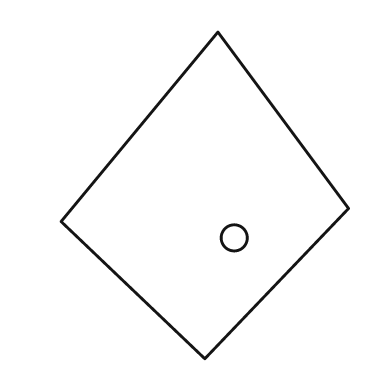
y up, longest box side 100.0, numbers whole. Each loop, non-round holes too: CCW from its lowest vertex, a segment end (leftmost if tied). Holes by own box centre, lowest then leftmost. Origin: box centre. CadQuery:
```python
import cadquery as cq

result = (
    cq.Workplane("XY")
    .moveTo(0.0, -50.0)
    .lineTo(44.0, -4.0)
    .lineTo(4.0, 50.0)
    .lineTo(-44.0, -8.0)
    .close()
    .moveTo(9.0, -13.0)
    .circle(4.0)
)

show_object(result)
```